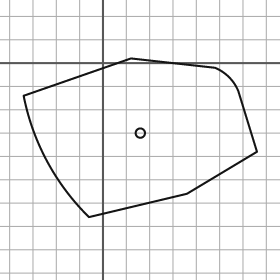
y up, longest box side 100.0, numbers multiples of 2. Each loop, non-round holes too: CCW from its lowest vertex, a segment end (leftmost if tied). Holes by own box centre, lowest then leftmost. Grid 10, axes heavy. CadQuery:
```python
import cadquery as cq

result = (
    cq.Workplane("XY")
    .moveTo(-6.0, -66.0)
    .lineTo(36.0, -56.0)
    .lineTo(66.0, -38.0)
    .lineTo(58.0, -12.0)
    .threePointArc((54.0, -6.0), (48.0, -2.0))
    .lineTo(12.0, 2.0)
    .lineTo(-34.0, -14.0)
    .threePointArc((-24.0, -42.0), (-6.0, -66.0))
    .close()
    .moveTo(16.0, -30.0)
    .circle(2.0)
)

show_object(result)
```